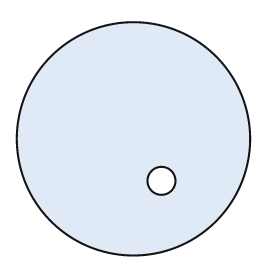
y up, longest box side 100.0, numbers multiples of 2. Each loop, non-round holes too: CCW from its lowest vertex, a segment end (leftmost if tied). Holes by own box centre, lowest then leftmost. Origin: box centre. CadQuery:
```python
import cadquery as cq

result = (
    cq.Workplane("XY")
    .moveTo(0.0, 0.0)
    .circle(50.0)
    .moveTo(12.0, -18.0)
    .circle(6.0)
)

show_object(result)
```